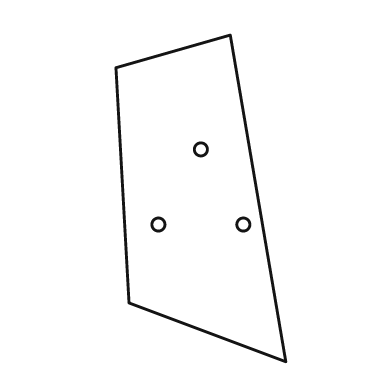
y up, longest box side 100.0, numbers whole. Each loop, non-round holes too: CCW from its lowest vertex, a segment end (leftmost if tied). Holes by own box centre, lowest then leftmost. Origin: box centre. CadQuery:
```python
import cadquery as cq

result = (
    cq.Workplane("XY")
    .moveTo(26.0, -50.0)
    .lineTo(9.0, 50.0)
    .lineTo(-26.0, 40.0)
    .lineTo(-22.0, -32.0)
    .close()
    .moveTo(-13.0, -8.0)
    .circle(2.0)
    .moveTo(13.0, -8.0)
    .circle(2.0)
    .moveTo(0.0, 15.0)
    .circle(2.0)
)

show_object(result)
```